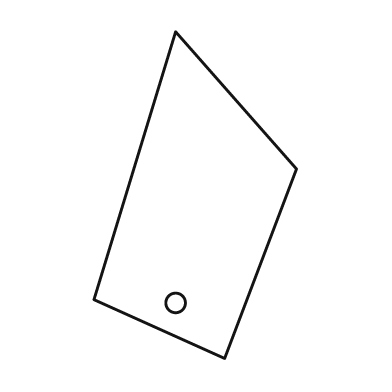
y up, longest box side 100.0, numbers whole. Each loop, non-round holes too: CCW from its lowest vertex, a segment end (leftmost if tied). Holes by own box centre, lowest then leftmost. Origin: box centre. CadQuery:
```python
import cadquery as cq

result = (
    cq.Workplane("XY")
    .moveTo(9.0, -50.0)
    .lineTo(31.0, 8.0)
    .lineTo(-6.0, 50.0)
    .lineTo(-31.0, -32.0)
    .close()
    .moveTo(-6.0, -33.0)
    .circle(3.0)
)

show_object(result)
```